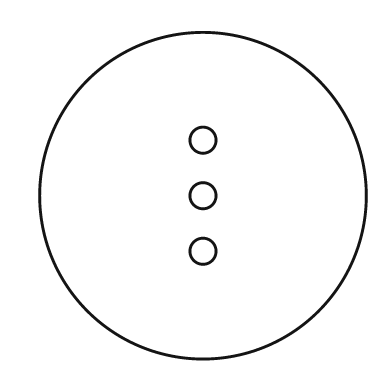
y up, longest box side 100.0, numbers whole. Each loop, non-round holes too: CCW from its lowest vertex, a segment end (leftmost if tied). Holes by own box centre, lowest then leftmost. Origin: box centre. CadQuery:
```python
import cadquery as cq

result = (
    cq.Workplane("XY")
    .moveTo(0.0, 0.0)
    .circle(50.0)
    .moveTo(0.0, -17.0)
    .circle(4.0)
    .moveTo(0.0, 0.0)
    .circle(4.0)
    .moveTo(0.0, 17.0)
    .circle(4.0)
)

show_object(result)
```